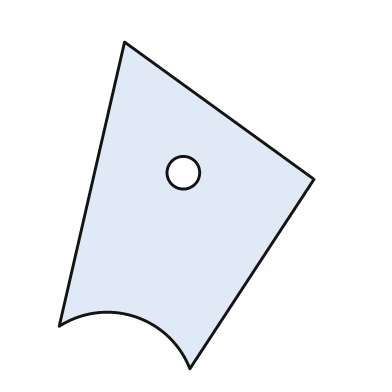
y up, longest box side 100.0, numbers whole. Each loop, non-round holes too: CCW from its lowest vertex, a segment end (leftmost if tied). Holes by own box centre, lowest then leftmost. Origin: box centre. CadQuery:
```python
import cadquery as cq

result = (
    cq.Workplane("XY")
    .moveTo(1.0, -50.0)
    .lineTo(39.0, 8.0)
    .lineTo(-19.0, 50.0)
    .lineTo(-39.0, -37.0)
    .threePointArc((-16.0, -34.0), (1.0, -50.0))
    .close()
    .moveTo(-1.0, 10.0)
    .circle(5.0)
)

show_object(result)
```